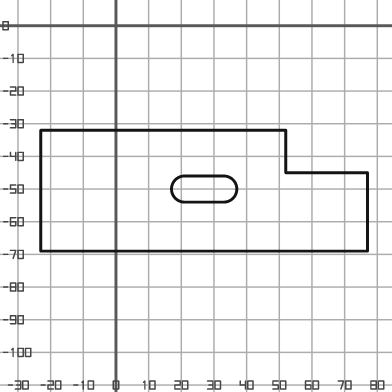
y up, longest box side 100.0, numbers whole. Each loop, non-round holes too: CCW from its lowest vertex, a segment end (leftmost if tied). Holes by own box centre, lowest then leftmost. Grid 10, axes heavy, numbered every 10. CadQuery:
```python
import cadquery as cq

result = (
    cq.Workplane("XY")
    .moveTo(-23.0, -69.0)
    .lineTo(77.0, -69.0)
    .lineTo(77.0, -45.0)
    .lineTo(52.0, -45.0)
    .lineTo(52.0, -32.0)
    .lineTo(-23.0, -32.0)
    .close()
    .moveTo(21.0, -54.0)
    .lineTo(33.0, -54.0)
    .threePointArc((37.0, -50.0), (33.0, -46.0))
    .lineTo(21.0, -46.0)
    .threePointArc((17.0, -50.0), (21.0, -54.0))
    .close()
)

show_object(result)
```